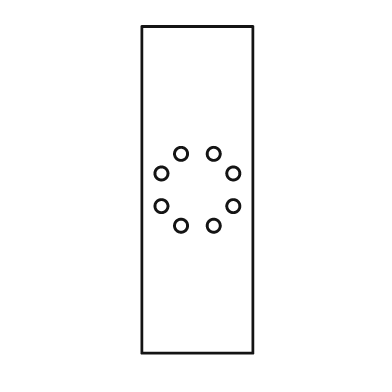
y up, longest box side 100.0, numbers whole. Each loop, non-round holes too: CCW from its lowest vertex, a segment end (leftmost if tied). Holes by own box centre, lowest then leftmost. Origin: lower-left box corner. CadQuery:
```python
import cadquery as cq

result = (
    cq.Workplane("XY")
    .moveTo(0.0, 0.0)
    .lineTo(34.0, 0.0)
    .lineTo(34.0, 100.0)
    .lineTo(0.0, 100.0)
    .close()
    .moveTo(12.0, 39.0)
    .circle(2.0)
    .moveTo(22.0, 39.0)
    .circle(2.0)
    .moveTo(6.0, 45.0)
    .circle(2.0)
    .moveTo(28.0, 45.0)
    .circle(2.0)
    .moveTo(6.0, 55.0)
    .circle(2.0)
    .moveTo(28.0, 55.0)
    .circle(2.0)
    .moveTo(12.0, 61.0)
    .circle(2.0)
    .moveTo(22.0, 61.0)
    .circle(2.0)
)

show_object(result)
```